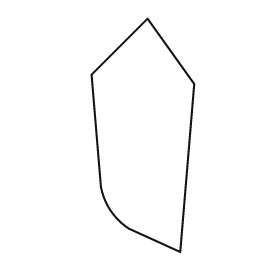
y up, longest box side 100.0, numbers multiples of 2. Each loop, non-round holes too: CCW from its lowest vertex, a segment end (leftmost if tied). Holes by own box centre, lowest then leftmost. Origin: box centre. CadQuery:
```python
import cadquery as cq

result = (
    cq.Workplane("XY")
    .moveTo(16.0, -50.0)
    .lineTo(22.0, 22.0)
    .lineTo(2.0, 50.0)
    .lineTo(-22.0, 26.0)
    .lineTo(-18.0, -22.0)
    .threePointArc((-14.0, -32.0), (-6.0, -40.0))
    .close()
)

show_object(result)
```